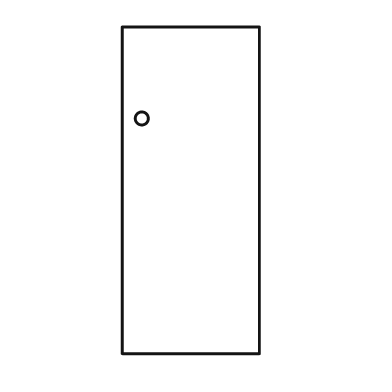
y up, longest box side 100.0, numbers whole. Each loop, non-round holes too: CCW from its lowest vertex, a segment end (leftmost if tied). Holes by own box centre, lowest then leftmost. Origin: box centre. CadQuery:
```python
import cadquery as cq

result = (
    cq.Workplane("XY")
    .moveTo(-21.0, -50.0)
    .lineTo(21.0, -50.0)
    .lineTo(21.0, 50.0)
    .lineTo(-21.0, 50.0)
    .close()
    .moveTo(-15.0, 22.0)
    .circle(2.0)
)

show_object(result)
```